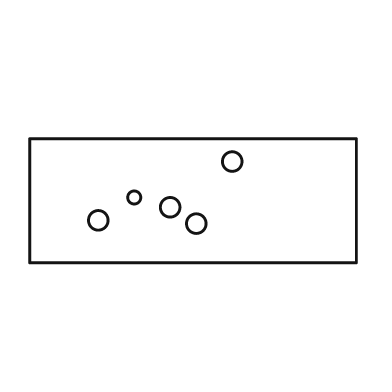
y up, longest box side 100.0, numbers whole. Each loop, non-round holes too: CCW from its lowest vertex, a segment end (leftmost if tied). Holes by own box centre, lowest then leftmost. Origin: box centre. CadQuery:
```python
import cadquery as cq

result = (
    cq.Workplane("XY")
    .moveTo(-50.0, -19.0)
    .lineTo(50.0, -19.0)
    .lineTo(50.0, 19.0)
    .lineTo(-50.0, 19.0)
    .close()
    .moveTo(1.0, -7.0)
    .circle(3.0)
    .moveTo(-29.0, -6.0)
    .circle(3.0)
    .moveTo(-7.0, -2.0)
    .circle(3.0)
    .moveTo(-18.0, 1.0)
    .circle(2.0)
    .moveTo(12.0, 12.0)
    .circle(3.0)
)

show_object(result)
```